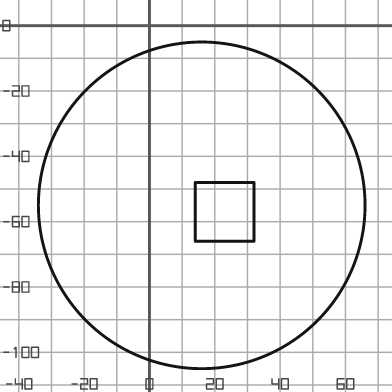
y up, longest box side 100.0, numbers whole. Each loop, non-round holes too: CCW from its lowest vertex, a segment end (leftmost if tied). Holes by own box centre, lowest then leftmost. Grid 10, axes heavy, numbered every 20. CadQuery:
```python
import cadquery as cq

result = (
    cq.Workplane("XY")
    .moveTo(16.0, -55.0)
    .circle(50.0)
    .moveTo(14.0, -66.0)
    .lineTo(32.0, -66.0)
    .lineTo(32.0, -48.0)
    .lineTo(14.0, -48.0)
    .close()
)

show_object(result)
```